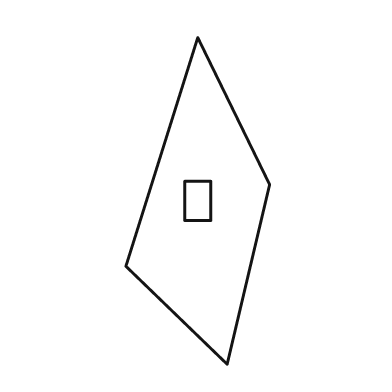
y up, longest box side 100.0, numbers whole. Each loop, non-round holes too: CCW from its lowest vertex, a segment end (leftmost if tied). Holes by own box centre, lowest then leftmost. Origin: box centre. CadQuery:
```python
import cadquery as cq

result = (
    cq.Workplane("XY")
    .moveTo(9.0, -50.0)
    .lineTo(22.0, 5.0)
    .lineTo(0.0, 50.0)
    .lineTo(-22.0, -20.0)
    .close()
    .moveTo(-4.0, -6.0)
    .lineTo(4.0, -6.0)
    .lineTo(4.0, 6.0)
    .lineTo(-4.0, 6.0)
    .close()
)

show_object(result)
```